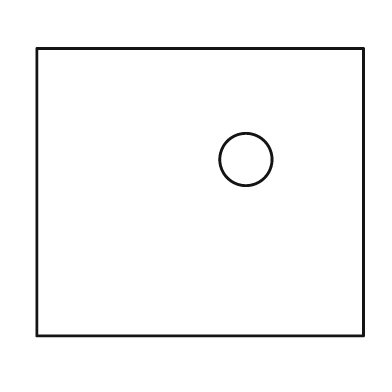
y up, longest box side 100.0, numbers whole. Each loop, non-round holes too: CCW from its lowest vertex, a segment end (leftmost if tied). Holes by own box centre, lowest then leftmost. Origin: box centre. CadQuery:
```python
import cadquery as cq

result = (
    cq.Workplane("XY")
    .moveTo(-50.0, -44.0)
    .lineTo(50.0, -44.0)
    .lineTo(50.0, 44.0)
    .lineTo(-50.0, 44.0)
    .close()
    .moveTo(14.0, 10.0)
    .circle(8.0)
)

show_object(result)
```